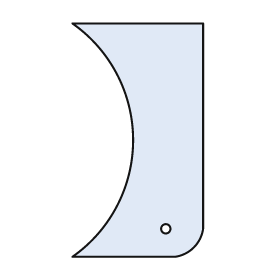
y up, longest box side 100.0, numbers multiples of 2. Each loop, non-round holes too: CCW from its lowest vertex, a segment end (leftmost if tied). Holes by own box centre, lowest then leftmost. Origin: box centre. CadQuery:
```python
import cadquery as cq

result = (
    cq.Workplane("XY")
    .moveTo(-28.0, -50.0)
    .lineTo(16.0, -50.0)
    .threePointArc((24.0, -46.0), (28.0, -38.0))
    .lineTo(28.0, 50.0)
    .lineTo(-28.0, 50.0)
    .threePointArc((-2.0, 0.0), (-28.0, -50.0))
    .close()
    .moveTo(12.0, -38.0)
    .circle(2.0)
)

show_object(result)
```